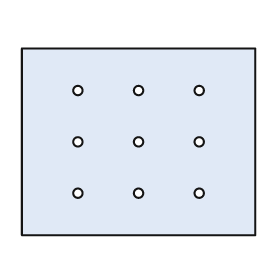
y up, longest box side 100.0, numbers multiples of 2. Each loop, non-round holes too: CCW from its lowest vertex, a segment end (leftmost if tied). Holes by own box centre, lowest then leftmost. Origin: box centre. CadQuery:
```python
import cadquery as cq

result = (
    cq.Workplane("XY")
    .moveTo(-50.0, -40.0)
    .lineTo(50.0, -40.0)
    .lineTo(50.0, 40.0)
    .lineTo(-50.0, 40.0)
    .close()
    .moveTo(-26.0, -22.0)
    .circle(2.0)
    .moveTo(0.0, -22.0)
    .circle(2.0)
    .moveTo(26.0, -22.0)
    .circle(2.0)
    .moveTo(-26.0, 0.0)
    .circle(2.0)
    .moveTo(0.0, 0.0)
    .circle(2.0)
    .moveTo(26.0, 0.0)
    .circle(2.0)
    .moveTo(-26.0, 22.0)
    .circle(2.0)
    .moveTo(0.0, 22.0)
    .circle(2.0)
    .moveTo(26.0, 22.0)
    .circle(2.0)
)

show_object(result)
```